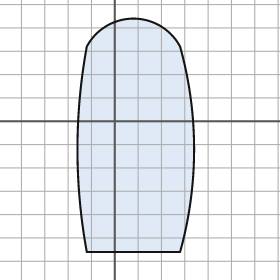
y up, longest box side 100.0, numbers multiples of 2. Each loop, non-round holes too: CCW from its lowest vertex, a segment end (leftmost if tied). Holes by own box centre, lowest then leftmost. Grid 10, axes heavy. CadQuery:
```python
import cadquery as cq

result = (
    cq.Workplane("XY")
    .moveTo(-12.0, -56.0)
    .lineTo(28.0, -56.0)
    .threePointArc((34.0, -12.0), (28.0, 32.0))
    .threePointArc((8.0, 44.0), (-12.0, 32.0))
    .threePointArc((-16.0, -12.0), (-12.0, -56.0))
    .close()
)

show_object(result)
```